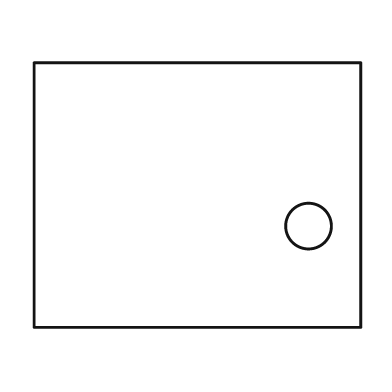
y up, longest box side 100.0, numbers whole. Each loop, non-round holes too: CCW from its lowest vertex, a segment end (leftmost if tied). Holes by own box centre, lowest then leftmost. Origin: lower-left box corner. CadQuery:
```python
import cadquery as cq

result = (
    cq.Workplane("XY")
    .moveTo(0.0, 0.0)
    .lineTo(100.0, 0.0)
    .lineTo(100.0, 81.0)
    .lineTo(0.0, 81.0)
    .close()
    .moveTo(84.0, 31.0)
    .circle(7.0)
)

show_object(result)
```